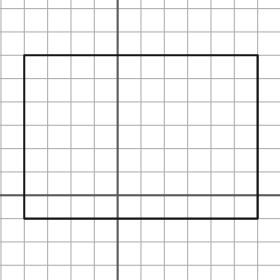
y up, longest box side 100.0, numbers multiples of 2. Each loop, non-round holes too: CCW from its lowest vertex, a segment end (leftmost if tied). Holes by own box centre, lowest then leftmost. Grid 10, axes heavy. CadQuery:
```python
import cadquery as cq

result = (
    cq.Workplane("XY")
    .moveTo(-40.0, -10.0)
    .lineTo(60.0, -10.0)
    .lineTo(60.0, 60.0)
    .lineTo(-40.0, 60.0)
    .close()
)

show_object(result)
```